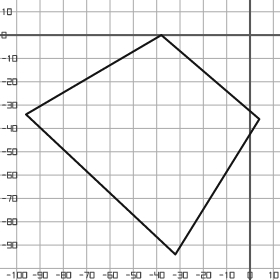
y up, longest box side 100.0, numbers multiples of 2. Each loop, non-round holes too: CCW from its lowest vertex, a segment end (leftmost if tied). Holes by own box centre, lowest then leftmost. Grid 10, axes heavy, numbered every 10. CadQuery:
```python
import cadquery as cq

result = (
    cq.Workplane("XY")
    .moveTo(-32.0, -94.0)
    .lineTo(4.0, -36.0)
    .lineTo(-38.0, 0.0)
    .lineTo(-96.0, -34.0)
    .close()
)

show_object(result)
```